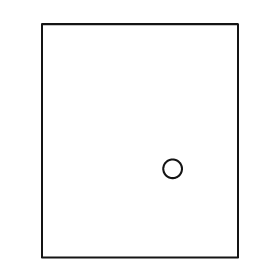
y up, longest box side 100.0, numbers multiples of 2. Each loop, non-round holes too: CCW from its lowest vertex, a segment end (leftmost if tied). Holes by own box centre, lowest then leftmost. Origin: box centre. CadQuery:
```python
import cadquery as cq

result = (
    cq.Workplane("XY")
    .moveTo(-42.0, -50.0)
    .lineTo(42.0, -50.0)
    .lineTo(42.0, 50.0)
    .lineTo(-42.0, 50.0)
    .close()
    .moveTo(14.0, -12.0)
    .circle(4.0)
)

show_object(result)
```